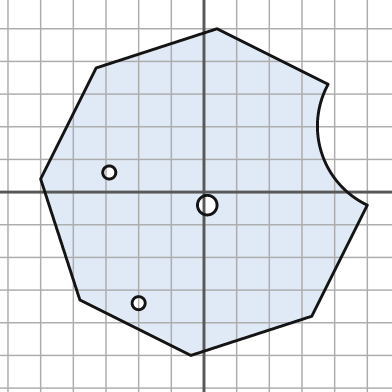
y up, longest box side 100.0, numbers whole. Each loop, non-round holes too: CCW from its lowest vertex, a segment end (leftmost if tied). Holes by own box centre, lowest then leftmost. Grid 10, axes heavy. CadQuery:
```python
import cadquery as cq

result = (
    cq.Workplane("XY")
    .moveTo(-4.0, -50.0)
    .lineTo(33.0, -38.0)
    .lineTo(50.0, -4.0)
    .threePointArc((36.0, 12.0), (38.0, 33.0))
    .lineTo(4.0, 50.0)
    .lineTo(-33.0, 38.0)
    .lineTo(-50.0, 4.0)
    .lineTo(-38.0, -33.0)
    .close()
    .moveTo(-20.0, -34.0)
    .circle(2.0)
    .moveTo(1.0, -4.0)
    .circle(3.0)
    .moveTo(-29.0, 6.0)
    .circle(2.0)
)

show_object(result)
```